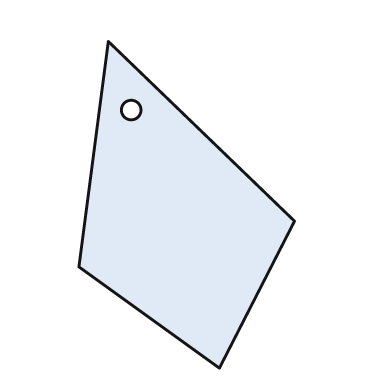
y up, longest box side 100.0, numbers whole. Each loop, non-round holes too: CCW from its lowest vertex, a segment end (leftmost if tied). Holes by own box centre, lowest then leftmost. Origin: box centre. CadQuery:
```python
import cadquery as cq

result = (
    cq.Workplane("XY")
    .moveTo(10.0, -50.0)
    .lineTo(33.0, -5.0)
    .lineTo(-24.0, 50.0)
    .lineTo(-33.0, -19.0)
    .close()
    .moveTo(-17.0, 29.0)
    .circle(3.0)
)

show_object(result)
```